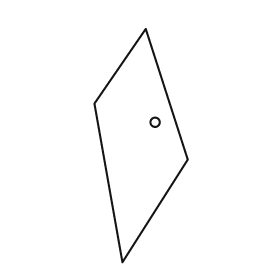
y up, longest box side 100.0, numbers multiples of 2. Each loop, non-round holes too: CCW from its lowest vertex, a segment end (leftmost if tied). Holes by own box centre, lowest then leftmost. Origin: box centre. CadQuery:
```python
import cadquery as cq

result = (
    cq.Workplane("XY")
    .moveTo(-8.0, -50.0)
    .lineTo(20.0, -6.0)
    .lineTo(2.0, 50.0)
    .lineTo(-20.0, 18.0)
    .close()
    .moveTo(6.0, 10.0)
    .circle(2.0)
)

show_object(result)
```